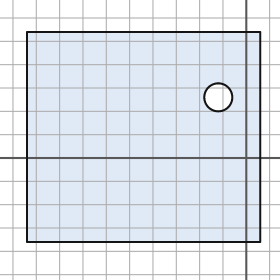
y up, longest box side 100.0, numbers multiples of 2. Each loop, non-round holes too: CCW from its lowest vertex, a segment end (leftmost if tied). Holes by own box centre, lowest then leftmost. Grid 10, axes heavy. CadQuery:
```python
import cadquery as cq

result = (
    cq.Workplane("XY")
    .moveTo(-94.0, -36.0)
    .lineTo(6.0, -36.0)
    .lineTo(6.0, 54.0)
    .lineTo(-94.0, 54.0)
    .close()
    .moveTo(-12.0, 26.0)
    .circle(6.0)
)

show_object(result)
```